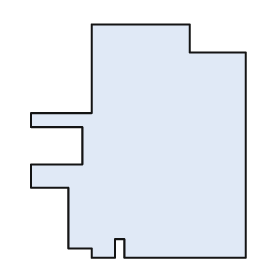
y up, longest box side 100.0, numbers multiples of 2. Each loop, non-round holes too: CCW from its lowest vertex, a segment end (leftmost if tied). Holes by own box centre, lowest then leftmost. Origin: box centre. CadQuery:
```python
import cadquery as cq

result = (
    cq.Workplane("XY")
    .moveTo(-20.0, -50.0)
    .lineTo(-10.0, -50.0)
    .lineTo(-10.0, -42.0)
    .lineTo(-6.0, -42.0)
    .lineTo(-6.0, -50.0)
    .lineTo(46.0, -50.0)
    .lineTo(46.0, 38.0)
    .lineTo(22.0, 38.0)
    .lineTo(22.0, 50.0)
    .lineTo(-20.0, 50.0)
    .lineTo(-20.0, 12.0)
    .lineTo(-46.0, 12.0)
    .lineTo(-46.0, 6.0)
    .lineTo(-24.0, 6.0)
    .lineTo(-24.0, -10.0)
    .lineTo(-46.0, -10.0)
    .lineTo(-46.0, -20.0)
    .lineTo(-30.0, -20.0)
    .lineTo(-30.0, -46.0)
    .lineTo(-20.0, -46.0)
    .close()
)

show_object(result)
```